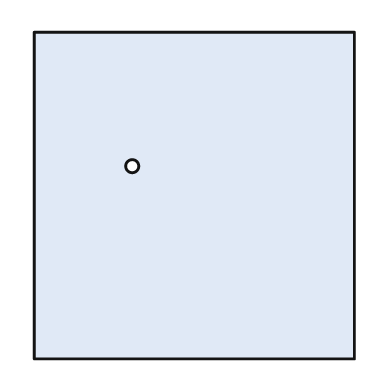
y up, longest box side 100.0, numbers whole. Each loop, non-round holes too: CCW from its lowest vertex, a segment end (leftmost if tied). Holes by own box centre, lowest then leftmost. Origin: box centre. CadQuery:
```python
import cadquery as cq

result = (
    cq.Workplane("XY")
    .moveTo(-49.0, -50.0)
    .lineTo(49.0, -50.0)
    .lineTo(49.0, 50.0)
    .lineTo(-49.0, 50.0)
    .close()
    .moveTo(-19.0, 9.0)
    .circle(2.0)
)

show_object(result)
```